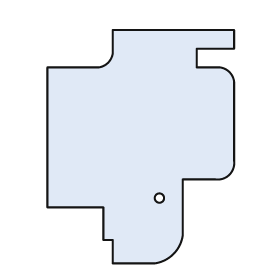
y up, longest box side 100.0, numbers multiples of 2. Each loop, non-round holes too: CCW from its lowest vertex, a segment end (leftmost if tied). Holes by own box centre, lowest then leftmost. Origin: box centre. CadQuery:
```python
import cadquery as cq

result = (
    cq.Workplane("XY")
    .moveTo(-12.0, -50.0)
    .lineTo(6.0, -50.0)
    .threePointArc((14.0, -46.0), (18.0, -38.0))
    .lineTo(18.0, -14.0)
    .lineTo(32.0, -14.0)
    .threePointArc((38.0, -12.0), (40.0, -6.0))
    .lineTo(40.0, 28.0)
    .threePointArc((38.0, 32.0), (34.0, 34.0))
    .lineTo(24.0, 34.0)
    .lineTo(24.0, 42.0)
    .lineTo(40.0, 42.0)
    .lineTo(40.0, 50.0)
    .lineTo(-12.0, 50.0)
    .lineTo(-12.0, 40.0)
    .threePointArc((-14.0, 36.0), (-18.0, 34.0))
    .lineTo(-40.0, 34.0)
    .lineTo(-40.0, -26.0)
    .lineTo(-16.0, -26.0)
    .lineTo(-16.0, -40.0)
    .lineTo(-12.0, -40.0)
    .close()
    .moveTo(8.0, -22.0)
    .circle(2.0)
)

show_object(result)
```